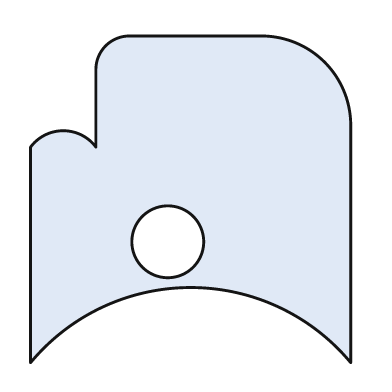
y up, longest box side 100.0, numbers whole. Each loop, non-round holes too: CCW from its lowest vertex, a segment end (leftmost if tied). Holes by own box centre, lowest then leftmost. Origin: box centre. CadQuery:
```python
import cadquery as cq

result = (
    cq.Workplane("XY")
    .moveTo(-49.0, -50.0)
    .threePointArc((0.0, -27.0), (49.0, -50.0))
    .lineTo(49.0, 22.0)
    .threePointArc((41.0, 42.0), (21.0, 50.0))
    .lineTo(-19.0, 50.0)
    .threePointArc((-26.0, 47.0), (-29.0, 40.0))
    .lineTo(-29.0, 16.0)
    .threePointArc((-39.0, 21.0), (-49.0, 16.0))
    .close()
    .moveTo(-7.0, -13.0)
    .circle(11.0)
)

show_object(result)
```